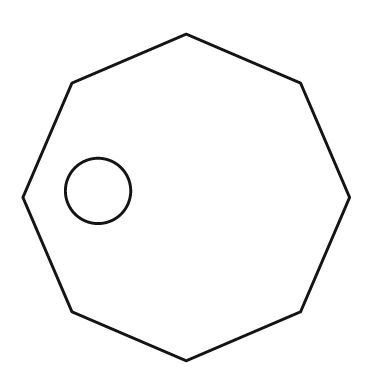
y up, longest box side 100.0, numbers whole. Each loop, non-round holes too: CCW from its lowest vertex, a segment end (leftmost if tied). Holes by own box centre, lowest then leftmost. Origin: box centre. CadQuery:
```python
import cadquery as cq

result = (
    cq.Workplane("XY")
    .moveTo(0.0, -50.0)
    .lineTo(35.0, -35.0)
    .lineTo(50.0, 0.0)
    .lineTo(35.0, 35.0)
    .lineTo(0.0, 50.0)
    .lineTo(-35.0, 35.0)
    .lineTo(-50.0, 0.0)
    .lineTo(-35.0, -35.0)
    .close()
    .moveTo(-27.0, 2.0)
    .circle(10.0)
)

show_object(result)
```